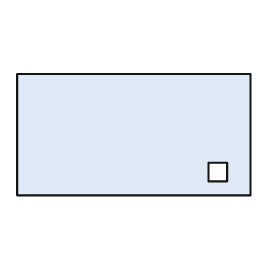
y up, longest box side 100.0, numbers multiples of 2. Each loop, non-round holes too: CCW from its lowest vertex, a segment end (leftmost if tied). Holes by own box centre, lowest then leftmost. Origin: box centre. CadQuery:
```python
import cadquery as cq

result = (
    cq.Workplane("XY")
    .moveTo(-50.0, -26.0)
    .lineTo(50.0, -26.0)
    .lineTo(50.0, 26.0)
    .lineTo(-50.0, 26.0)
    .close()
    .moveTo(32.0, -20.0)
    .lineTo(40.0, -20.0)
    .lineTo(40.0, -12.0)
    .lineTo(32.0, -12.0)
    .close()
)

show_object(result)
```